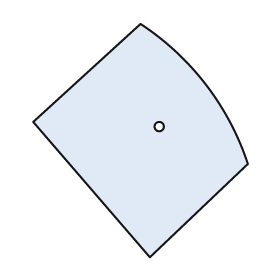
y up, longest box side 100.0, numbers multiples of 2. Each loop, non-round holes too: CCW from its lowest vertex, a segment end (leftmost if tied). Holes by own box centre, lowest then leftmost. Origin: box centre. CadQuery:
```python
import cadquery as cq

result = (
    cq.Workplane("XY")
    .moveTo(4.0, -50.0)
    .lineTo(46.0, -10.0)
    .threePointArc((28.0, 24.0), (0.0, 50.0))
    .lineTo(-46.0, 8.0)
    .close()
    .moveTo(8.0, 6.0)
    .circle(2.0)
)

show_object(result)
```